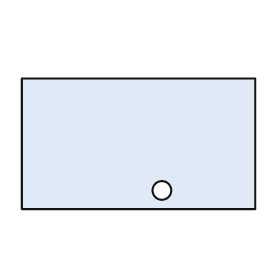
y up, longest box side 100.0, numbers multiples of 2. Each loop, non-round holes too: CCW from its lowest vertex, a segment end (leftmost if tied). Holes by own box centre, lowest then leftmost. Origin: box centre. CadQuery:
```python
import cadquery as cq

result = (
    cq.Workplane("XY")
    .moveTo(-50.0, -28.0)
    .lineTo(50.0, -28.0)
    .lineTo(50.0, 28.0)
    .lineTo(-50.0, 28.0)
    .close()
    .moveTo(10.0, -20.0)
    .circle(4.0)
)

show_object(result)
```